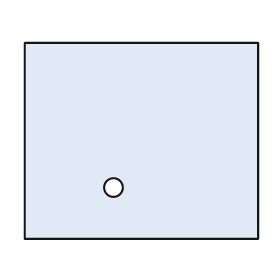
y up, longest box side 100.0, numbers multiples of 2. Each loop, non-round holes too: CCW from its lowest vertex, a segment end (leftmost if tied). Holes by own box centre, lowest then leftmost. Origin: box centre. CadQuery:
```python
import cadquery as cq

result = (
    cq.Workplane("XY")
    .moveTo(-50.0, -42.0)
    .lineTo(50.0, -42.0)
    .lineTo(50.0, 42.0)
    .lineTo(-50.0, 42.0)
    .close()
    .moveTo(-12.0, -20.0)
    .circle(4.0)
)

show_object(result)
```